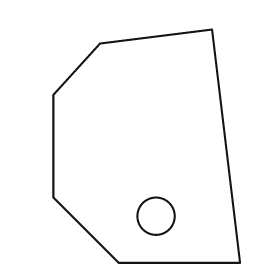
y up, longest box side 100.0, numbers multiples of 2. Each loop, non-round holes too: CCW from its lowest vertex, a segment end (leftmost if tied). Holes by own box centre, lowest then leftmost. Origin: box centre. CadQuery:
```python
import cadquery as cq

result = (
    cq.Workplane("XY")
    .moveTo(-12.0, -50.0)
    .lineTo(40.0, -50.0)
    .lineTo(28.0, 50.0)
    .lineTo(-20.0, 44.0)
    .lineTo(-40.0, 22.0)
    .lineTo(-40.0, -22.0)
    .close()
    .moveTo(4.0, -30.0)
    .circle(8.0)
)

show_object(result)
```